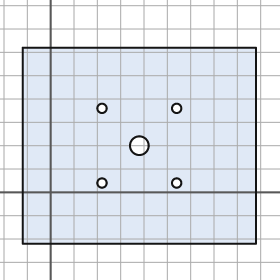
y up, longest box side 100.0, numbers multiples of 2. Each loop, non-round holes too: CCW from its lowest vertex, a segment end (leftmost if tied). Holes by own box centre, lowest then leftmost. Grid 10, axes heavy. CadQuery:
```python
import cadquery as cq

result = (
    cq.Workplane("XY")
    .moveTo(-12.0, -22.0)
    .lineTo(88.0, -22.0)
    .lineTo(88.0, 62.0)
    .lineTo(-12.0, 62.0)
    .close()
    .moveTo(22.0, 4.0)
    .circle(2.0)
    .moveTo(54.0, 4.0)
    .circle(2.0)
    .moveTo(38.0, 20.0)
    .circle(4.0)
    .moveTo(22.0, 36.0)
    .circle(2.0)
    .moveTo(54.0, 36.0)
    .circle(2.0)
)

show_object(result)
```